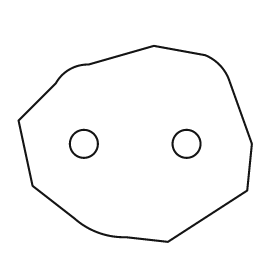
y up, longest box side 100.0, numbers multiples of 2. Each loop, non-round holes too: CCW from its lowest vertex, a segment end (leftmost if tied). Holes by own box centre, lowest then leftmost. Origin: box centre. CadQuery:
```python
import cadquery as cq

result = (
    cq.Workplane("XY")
    .moveTo(14.0, -42.0)
    .lineTo(48.0, -20.0)
    .lineTo(50.0, 0.0)
    .lineTo(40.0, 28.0)
    .threePointArc((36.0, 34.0), (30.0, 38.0))
    .lineTo(8.0, 42.0)
    .lineTo(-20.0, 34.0)
    .threePointArc((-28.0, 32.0), (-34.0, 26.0))
    .lineTo(-50.0, 10.0)
    .lineTo(-44.0, -18.0)
    .lineTo(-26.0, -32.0)
    .threePointArc((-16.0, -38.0), (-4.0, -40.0))
    .close()
    .moveTo(-22.0, 0.0)
    .circle(6.0)
    .moveTo(22.0, 0.0)
    .circle(6.0)
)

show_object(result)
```